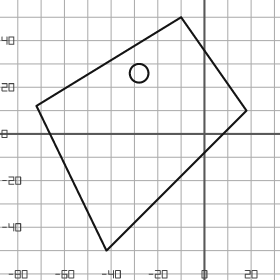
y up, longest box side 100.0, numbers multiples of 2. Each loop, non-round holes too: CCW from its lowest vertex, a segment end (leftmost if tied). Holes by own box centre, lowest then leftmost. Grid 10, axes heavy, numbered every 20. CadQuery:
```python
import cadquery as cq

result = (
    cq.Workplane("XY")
    .moveTo(-42.0, -50.0)
    .lineTo(18.0, 10.0)
    .lineTo(-10.0, 50.0)
    .lineTo(-72.0, 12.0)
    .close()
    .moveTo(-28.0, 26.0)
    .circle(4.0)
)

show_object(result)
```